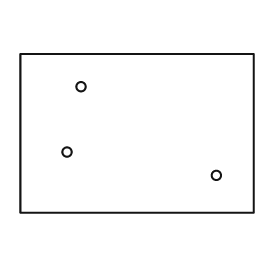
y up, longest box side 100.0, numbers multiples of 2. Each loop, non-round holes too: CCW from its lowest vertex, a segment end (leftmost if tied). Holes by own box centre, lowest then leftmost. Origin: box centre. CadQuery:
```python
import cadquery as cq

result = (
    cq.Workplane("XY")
    .moveTo(-50.0, -34.0)
    .lineTo(50.0, -34.0)
    .lineTo(50.0, 34.0)
    .lineTo(-50.0, 34.0)
    .close()
    .moveTo(34.0, -18.0)
    .circle(2.0)
    .moveTo(-30.0, -8.0)
    .circle(2.0)
    .moveTo(-24.0, 20.0)
    .circle(2.0)
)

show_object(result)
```